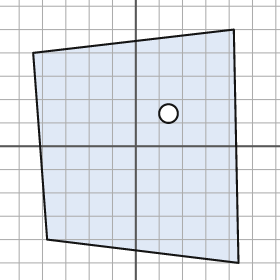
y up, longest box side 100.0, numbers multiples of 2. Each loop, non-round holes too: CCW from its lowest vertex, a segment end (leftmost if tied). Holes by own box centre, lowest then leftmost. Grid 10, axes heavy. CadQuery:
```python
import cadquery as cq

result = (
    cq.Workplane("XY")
    .moveTo(44.0, -50.0)
    .lineTo(42.0, 50.0)
    .lineTo(-44.0, 40.0)
    .lineTo(-38.0, -40.0)
    .close()
    .moveTo(14.0, 14.0)
    .circle(4.0)
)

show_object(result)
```